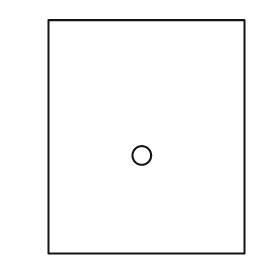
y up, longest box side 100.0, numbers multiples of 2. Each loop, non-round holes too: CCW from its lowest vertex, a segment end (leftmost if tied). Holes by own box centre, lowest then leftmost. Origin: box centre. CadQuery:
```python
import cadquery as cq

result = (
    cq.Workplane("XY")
    .moveTo(-42.0, -50.0)
    .lineTo(42.0, -50.0)
    .lineTo(42.0, 50.0)
    .lineTo(-42.0, 50.0)
    .close()
    .moveTo(-2.0, -8.0)
    .circle(4.0)
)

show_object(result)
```